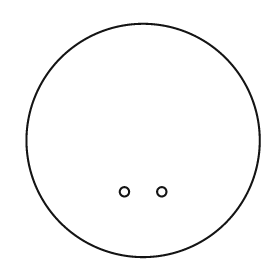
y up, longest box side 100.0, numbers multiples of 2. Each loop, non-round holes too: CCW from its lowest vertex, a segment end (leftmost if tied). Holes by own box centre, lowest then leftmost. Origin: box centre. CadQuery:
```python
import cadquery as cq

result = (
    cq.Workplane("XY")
    .moveTo(0.0, 0.0)
    .circle(50.0)
    .moveTo(-8.0, -22.0)
    .circle(2.0)
    .moveTo(8.0, -22.0)
    .circle(2.0)
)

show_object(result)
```